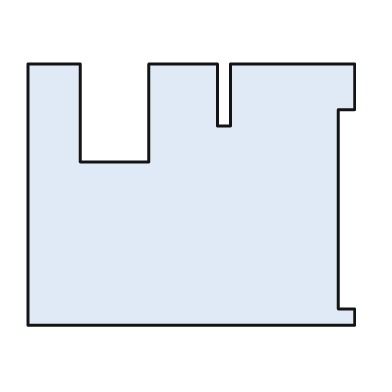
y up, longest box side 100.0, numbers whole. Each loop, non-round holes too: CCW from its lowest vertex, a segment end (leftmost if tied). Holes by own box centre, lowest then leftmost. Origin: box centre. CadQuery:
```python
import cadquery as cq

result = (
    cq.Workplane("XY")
    .moveTo(-50.0, -40.0)
    .lineTo(50.0, -40.0)
    .lineTo(50.0, -35.0)
    .lineTo(45.0, -35.0)
    .lineTo(45.0, 26.0)
    .lineTo(50.0, 26.0)
    .lineTo(50.0, 40.0)
    .lineTo(12.0, 40.0)
    .lineTo(12.0, 21.0)
    .lineTo(8.0, 21.0)
    .lineTo(8.0, 40.0)
    .lineTo(-13.0, 40.0)
    .lineTo(-13.0, 10.0)
    .lineTo(-34.0, 10.0)
    .lineTo(-34.0, 40.0)
    .lineTo(-50.0, 40.0)
    .close()
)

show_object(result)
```